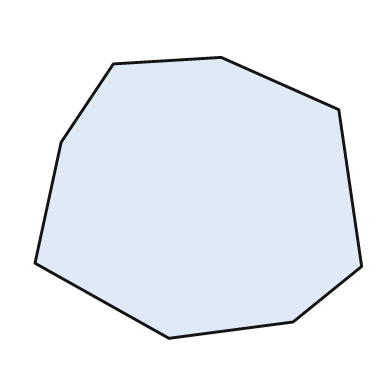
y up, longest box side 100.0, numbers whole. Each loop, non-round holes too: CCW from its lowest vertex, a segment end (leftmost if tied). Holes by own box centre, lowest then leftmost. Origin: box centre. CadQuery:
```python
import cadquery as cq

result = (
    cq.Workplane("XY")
    .moveTo(-9.0, -43.0)
    .lineTo(29.0, -38.0)
    .lineTo(50.0, -21.0)
    .lineTo(43.0, 27.0)
    .lineTo(7.0, 43.0)
    .lineTo(-26.0, 41.0)
    .lineTo(-42.0, 17.0)
    .lineTo(-50.0, -20.0)
    .close()
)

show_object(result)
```